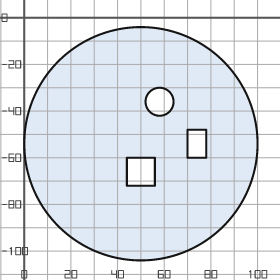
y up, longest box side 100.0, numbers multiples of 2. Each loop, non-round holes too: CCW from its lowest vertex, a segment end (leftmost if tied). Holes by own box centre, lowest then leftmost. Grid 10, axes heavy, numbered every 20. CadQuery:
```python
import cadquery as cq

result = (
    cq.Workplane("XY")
    .moveTo(50.0, -54.0)
    .circle(50.0)
    .moveTo(44.0, -72.0)
    .lineTo(56.0, -72.0)
    .lineTo(56.0, -60.0)
    .lineTo(44.0, -60.0)
    .close()
    .moveTo(70.0, -60.0)
    .lineTo(78.0, -60.0)
    .lineTo(78.0, -48.0)
    .lineTo(70.0, -48.0)
    .close()
    .moveTo(58.0, -36.0)
    .circle(6.0)
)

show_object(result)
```